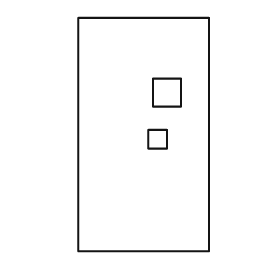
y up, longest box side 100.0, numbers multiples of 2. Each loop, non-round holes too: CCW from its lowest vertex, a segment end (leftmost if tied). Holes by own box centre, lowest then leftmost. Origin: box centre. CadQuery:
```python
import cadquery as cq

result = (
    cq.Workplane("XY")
    .moveTo(-28.0, -50.0)
    .lineTo(28.0, -50.0)
    .lineTo(28.0, 50.0)
    .lineTo(-28.0, 50.0)
    .close()
    .moveTo(2.0, -6.0)
    .lineTo(10.0, -6.0)
    .lineTo(10.0, 2.0)
    .lineTo(2.0, 2.0)
    .close()
    .moveTo(4.0, 12.0)
    .lineTo(16.0, 12.0)
    .lineTo(16.0, 24.0)
    .lineTo(4.0, 24.0)
    .close()
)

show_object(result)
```